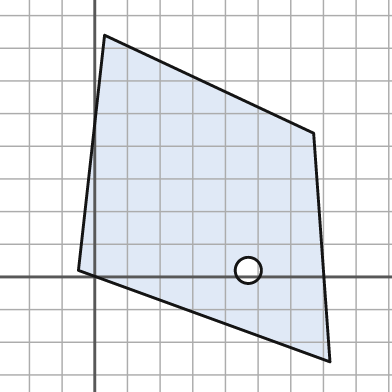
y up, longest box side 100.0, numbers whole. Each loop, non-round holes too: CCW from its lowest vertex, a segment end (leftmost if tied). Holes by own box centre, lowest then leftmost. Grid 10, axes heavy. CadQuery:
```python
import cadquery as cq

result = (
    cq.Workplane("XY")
    .moveTo(72.0, -26.0)
    .lineTo(67.0, 44.0)
    .lineTo(3.0, 74.0)
    .lineTo(-5.0, 2.0)
    .close()
    .moveTo(47.0, 2.0)
    .circle(4.0)
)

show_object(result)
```